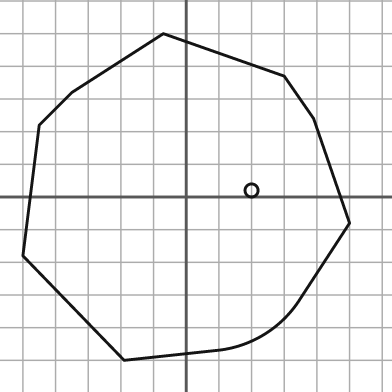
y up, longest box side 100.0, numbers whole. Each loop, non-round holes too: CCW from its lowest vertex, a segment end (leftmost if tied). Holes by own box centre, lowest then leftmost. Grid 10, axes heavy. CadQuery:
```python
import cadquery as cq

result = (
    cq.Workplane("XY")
    .moveTo(-19.0, -50.0)
    .lineTo(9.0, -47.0)
    .threePointArc((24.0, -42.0), (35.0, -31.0))
    .lineTo(50.0, -8.0)
    .lineTo(39.0, 24.0)
    .lineTo(30.0, 37.0)
    .lineTo(-7.0, 50.0)
    .lineTo(-35.0, 32.0)
    .lineTo(-45.0, 22.0)
    .lineTo(-50.0, -18.0)
    .close()
    .moveTo(20.0, 2.0)
    .circle(2.0)
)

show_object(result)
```